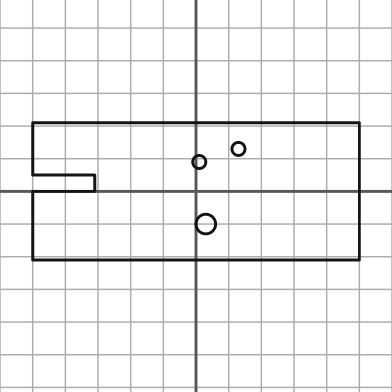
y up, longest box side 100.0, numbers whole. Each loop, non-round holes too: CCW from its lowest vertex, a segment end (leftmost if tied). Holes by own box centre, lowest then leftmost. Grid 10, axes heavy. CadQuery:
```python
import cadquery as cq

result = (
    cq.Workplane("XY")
    .moveTo(-50.0, -21.0)
    .lineTo(50.0, -21.0)
    .lineTo(50.0, 21.0)
    .lineTo(-50.0, 21.0)
    .lineTo(-50.0, 5.0)
    .lineTo(-31.0, 5.0)
    .lineTo(-31.0, 0.0)
    .lineTo(-50.0, 0.0)
    .close()
    .moveTo(3.0, -10.0)
    .circle(3.0)
    .moveTo(1.0, 9.0)
    .circle(2.0)
    .moveTo(13.0, 13.0)
    .circle(2.0)
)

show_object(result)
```